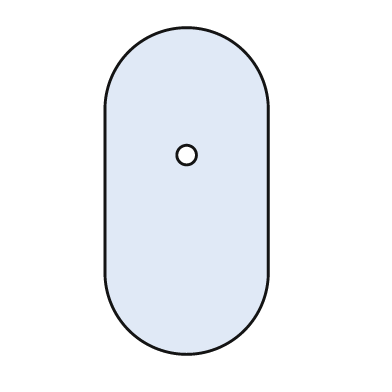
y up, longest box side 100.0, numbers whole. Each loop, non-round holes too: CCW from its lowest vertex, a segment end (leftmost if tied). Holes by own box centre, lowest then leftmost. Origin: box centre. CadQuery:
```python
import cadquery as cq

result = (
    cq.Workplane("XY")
    .moveTo(-25.0, -25.0)
    .threePointArc((0.0, -50.0), (25.0, -25.0))
    .lineTo(25.0, 25.0)
    .threePointArc((0.0, 50.0), (-25.0, 25.0))
    .close()
    .moveTo(0.0, 11.0)
    .circle(3.0)
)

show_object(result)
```